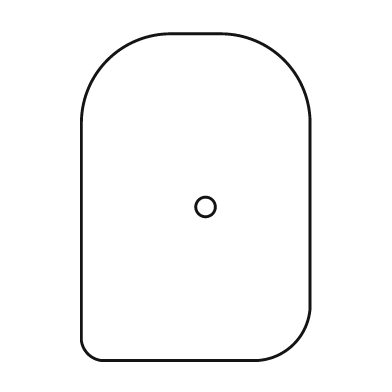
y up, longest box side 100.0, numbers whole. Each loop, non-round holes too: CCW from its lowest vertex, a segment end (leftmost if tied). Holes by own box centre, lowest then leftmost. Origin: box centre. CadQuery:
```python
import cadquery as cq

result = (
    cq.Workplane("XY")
    .moveTo(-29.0, -50.0)
    .lineTo(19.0, -50.0)
    .threePointArc((30.0, -45.0), (35.0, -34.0))
    .lineTo(35.0, 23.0)
    .threePointArc((27.0, 42.0), (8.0, 50.0))
    .lineTo(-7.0, 50.0)
    .threePointArc((-27.0, 42.0), (-35.0, 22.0))
    .lineTo(-35.0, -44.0)
    .threePointArc((-33.0, -48.0), (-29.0, -50.0))
    .close()
    .moveTo(3.0, -3.0)
    .circle(3.0)
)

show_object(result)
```